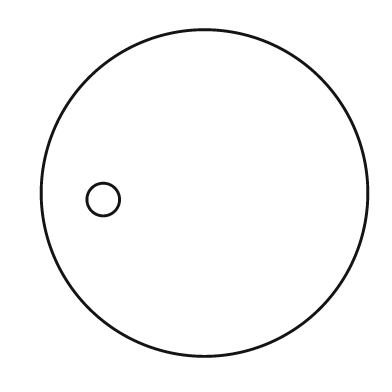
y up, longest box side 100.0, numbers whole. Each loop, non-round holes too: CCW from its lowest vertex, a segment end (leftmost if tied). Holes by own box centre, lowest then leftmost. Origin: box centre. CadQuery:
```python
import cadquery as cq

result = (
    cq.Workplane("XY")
    .moveTo(0.0, 0.0)
    .circle(50.0)
    .moveTo(-31.0, -2.0)
    .circle(5.0)
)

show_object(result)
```